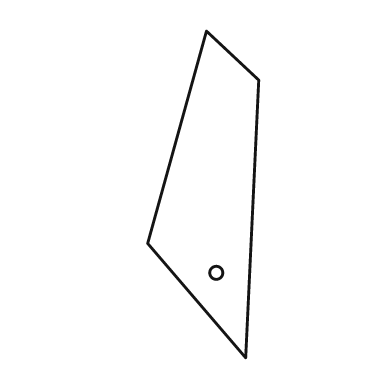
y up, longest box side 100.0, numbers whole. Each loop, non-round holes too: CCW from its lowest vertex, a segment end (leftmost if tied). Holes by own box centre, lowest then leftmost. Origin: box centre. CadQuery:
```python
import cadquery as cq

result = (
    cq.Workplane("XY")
    .moveTo(13.0, -50.0)
    .lineTo(17.0, 35.0)
    .lineTo(1.0, 50.0)
    .lineTo(-17.0, -15.0)
    .close()
    .moveTo(4.0, -24.0)
    .circle(2.0)
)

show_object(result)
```